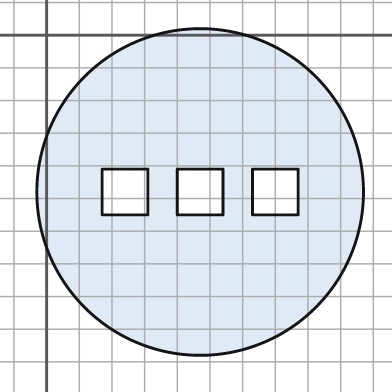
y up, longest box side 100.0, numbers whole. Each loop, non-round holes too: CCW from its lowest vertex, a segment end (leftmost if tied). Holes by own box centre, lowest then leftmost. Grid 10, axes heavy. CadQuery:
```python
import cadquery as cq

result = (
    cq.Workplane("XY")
    .moveTo(47.0, -48.0)
    .circle(50.0)
    .moveTo(17.0, -55.0)
    .lineTo(31.0, -55.0)
    .lineTo(31.0, -41.0)
    .lineTo(17.0, -41.0)
    .close()
    .moveTo(40.0, -55.0)
    .lineTo(54.0, -55.0)
    .lineTo(54.0, -41.0)
    .lineTo(40.0, -41.0)
    .close()
    .moveTo(63.0, -55.0)
    .lineTo(77.0, -55.0)
    .lineTo(77.0, -41.0)
    .lineTo(63.0, -41.0)
    .close()
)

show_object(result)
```